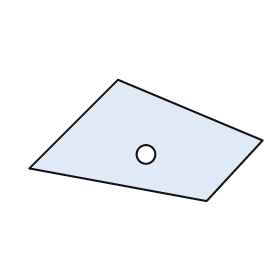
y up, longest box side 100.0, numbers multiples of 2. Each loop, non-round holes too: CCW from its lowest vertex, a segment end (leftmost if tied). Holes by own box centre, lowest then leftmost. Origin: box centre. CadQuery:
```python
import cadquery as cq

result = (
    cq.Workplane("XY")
    .moveTo(26.0, -26.0)
    .lineTo(50.0, 0.0)
    .lineTo(-12.0, 26.0)
    .lineTo(-50.0, -12.0)
    .close()
    .moveTo(0.0, -6.0)
    .circle(4.0)
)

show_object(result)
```